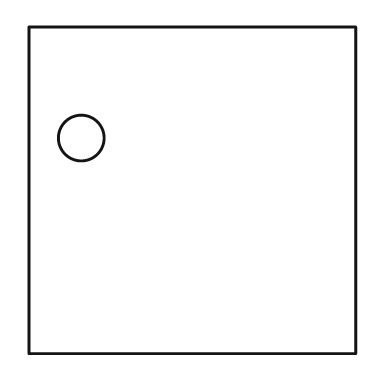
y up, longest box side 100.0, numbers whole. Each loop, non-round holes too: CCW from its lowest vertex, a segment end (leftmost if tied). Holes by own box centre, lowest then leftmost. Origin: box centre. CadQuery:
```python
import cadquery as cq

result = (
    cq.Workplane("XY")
    .moveTo(-50.0, -50.0)
    .lineTo(50.0, -50.0)
    .lineTo(50.0, 50.0)
    .lineTo(-50.0, 50.0)
    .close()
    .moveTo(-34.0, 16.0)
    .circle(7.0)
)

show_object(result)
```